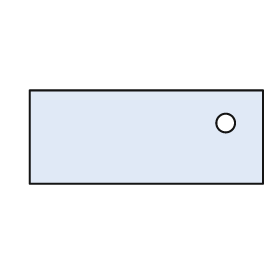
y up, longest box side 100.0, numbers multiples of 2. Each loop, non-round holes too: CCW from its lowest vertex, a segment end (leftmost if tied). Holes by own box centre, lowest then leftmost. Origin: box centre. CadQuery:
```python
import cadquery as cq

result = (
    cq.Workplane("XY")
    .moveTo(-50.0, -20.0)
    .lineTo(50.0, -20.0)
    .lineTo(50.0, 20.0)
    .lineTo(-50.0, 20.0)
    .close()
    .moveTo(34.0, 6.0)
    .circle(4.0)
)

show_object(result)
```